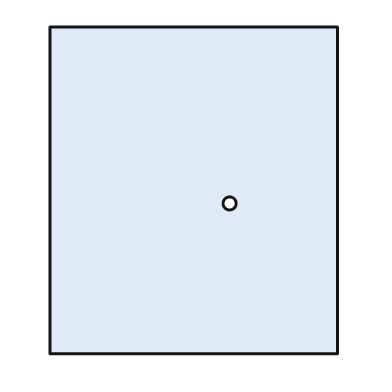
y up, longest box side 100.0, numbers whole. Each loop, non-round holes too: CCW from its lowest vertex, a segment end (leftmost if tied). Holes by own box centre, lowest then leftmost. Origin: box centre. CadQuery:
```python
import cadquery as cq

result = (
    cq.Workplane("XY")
    .moveTo(-44.0, -50.0)
    .lineTo(44.0, -50.0)
    .lineTo(44.0, 50.0)
    .lineTo(-44.0, 50.0)
    .close()
    .moveTo(11.0, -4.0)
    .circle(2.0)
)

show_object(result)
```